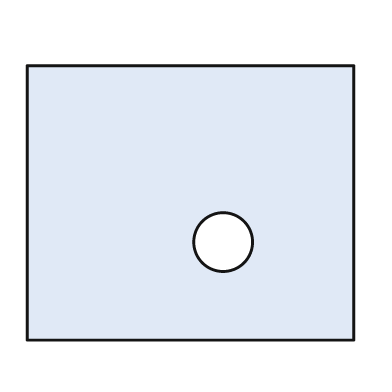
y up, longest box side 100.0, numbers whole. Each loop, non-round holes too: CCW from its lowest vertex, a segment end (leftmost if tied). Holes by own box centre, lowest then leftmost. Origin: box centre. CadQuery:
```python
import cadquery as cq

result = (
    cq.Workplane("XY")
    .moveTo(-50.0, -42.0)
    .lineTo(50.0, -42.0)
    .lineTo(50.0, 42.0)
    .lineTo(-50.0, 42.0)
    .close()
    .moveTo(10.0, -12.0)
    .circle(9.0)
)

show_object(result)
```